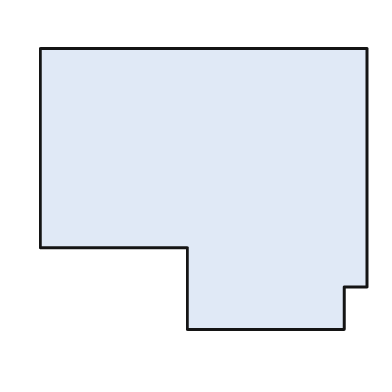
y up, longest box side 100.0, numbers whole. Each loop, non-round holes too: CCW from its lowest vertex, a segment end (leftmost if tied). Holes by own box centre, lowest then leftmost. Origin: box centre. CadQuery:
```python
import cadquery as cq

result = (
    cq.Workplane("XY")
    .moveTo(-5.0, -43.0)
    .lineTo(43.0, -43.0)
    .lineTo(43.0, -30.0)
    .lineTo(50.0, -30.0)
    .lineTo(50.0, 43.0)
    .lineTo(-50.0, 43.0)
    .lineTo(-50.0, -18.0)
    .lineTo(-5.0, -18.0)
    .close()
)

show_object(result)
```